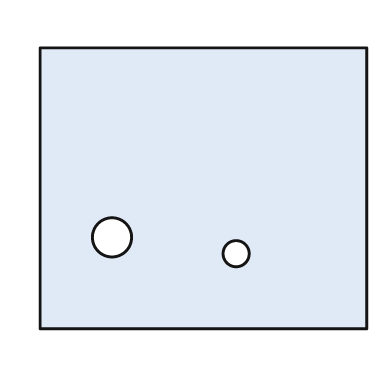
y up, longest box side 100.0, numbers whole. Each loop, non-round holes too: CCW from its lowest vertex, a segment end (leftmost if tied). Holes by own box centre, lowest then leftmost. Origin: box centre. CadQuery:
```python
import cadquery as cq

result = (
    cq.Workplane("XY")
    .moveTo(-50.0, -43.0)
    .lineTo(50.0, -43.0)
    .lineTo(50.0, 43.0)
    .lineTo(-50.0, 43.0)
    .close()
    .moveTo(10.0, -20.0)
    .circle(4.0)
    .moveTo(-28.0, -15.0)
    .circle(6.0)
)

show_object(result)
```